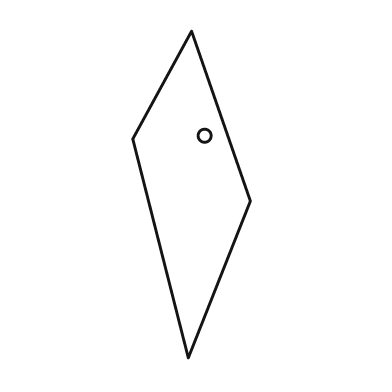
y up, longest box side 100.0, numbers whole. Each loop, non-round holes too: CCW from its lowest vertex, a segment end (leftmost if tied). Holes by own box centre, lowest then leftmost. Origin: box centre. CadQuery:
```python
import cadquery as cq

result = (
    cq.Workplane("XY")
    .moveTo(-1.0, -50.0)
    .lineTo(18.0, -2.0)
    .lineTo(0.0, 50.0)
    .lineTo(-18.0, 17.0)
    .close()
    .moveTo(4.0, 18.0)
    .circle(2.0)
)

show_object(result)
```